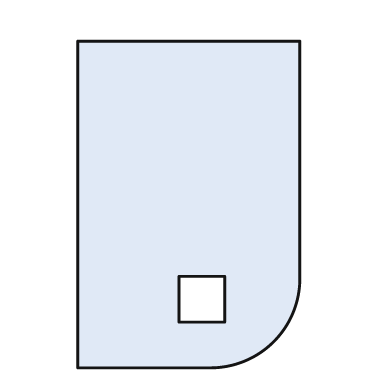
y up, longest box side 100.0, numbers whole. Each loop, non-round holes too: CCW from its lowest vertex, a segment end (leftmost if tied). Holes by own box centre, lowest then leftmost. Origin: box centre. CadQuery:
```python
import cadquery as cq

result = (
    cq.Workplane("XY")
    .moveTo(-34.0, -50.0)
    .lineTo(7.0, -50.0)
    .threePointArc((26.0, -42.0), (34.0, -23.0))
    .lineTo(34.0, 50.0)
    .lineTo(-34.0, 50.0)
    .close()
    .moveTo(-3.0, -36.0)
    .lineTo(11.0, -36.0)
    .lineTo(11.0, -22.0)
    .lineTo(-3.0, -22.0)
    .close()
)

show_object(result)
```